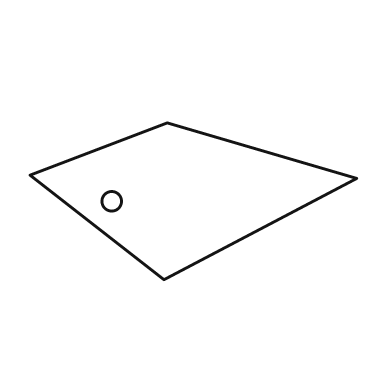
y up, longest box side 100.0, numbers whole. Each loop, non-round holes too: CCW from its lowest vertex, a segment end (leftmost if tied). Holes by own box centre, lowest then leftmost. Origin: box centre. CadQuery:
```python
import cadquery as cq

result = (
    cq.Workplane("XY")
    .moveTo(-9.0, -24.0)
    .lineTo(50.0, 7.0)
    .lineTo(-8.0, 24.0)
    .lineTo(-50.0, 8.0)
    .close()
    .moveTo(-25.0, 0.0)
    .circle(3.0)
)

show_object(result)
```